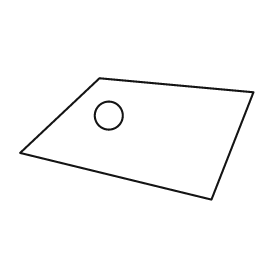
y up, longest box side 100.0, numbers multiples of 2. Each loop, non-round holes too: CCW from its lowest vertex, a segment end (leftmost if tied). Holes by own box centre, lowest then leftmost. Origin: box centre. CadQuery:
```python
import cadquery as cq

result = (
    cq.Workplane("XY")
    .moveTo(32.0, -26.0)
    .lineTo(50.0, 20.0)
    .lineTo(-16.0, 26.0)
    .lineTo(-50.0, -6.0)
    .close()
    .moveTo(-12.0, 10.0)
    .circle(6.0)
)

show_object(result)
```